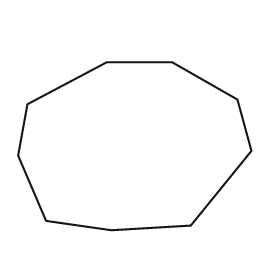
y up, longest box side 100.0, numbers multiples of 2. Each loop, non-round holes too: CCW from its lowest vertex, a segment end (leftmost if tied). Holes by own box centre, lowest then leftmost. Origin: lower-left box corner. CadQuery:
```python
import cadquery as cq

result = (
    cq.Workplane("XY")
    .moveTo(40.0, 0.0)
    .lineTo(74.0, 2.0)
    .lineTo(100.0, 34.0)
    .lineTo(94.0, 56.0)
    .lineTo(66.0, 72.0)
    .lineTo(38.0, 72.0)
    .lineTo(4.0, 54.0)
    .lineTo(0.0, 32.0)
    .lineTo(12.0, 4.0)
    .close()
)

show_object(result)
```